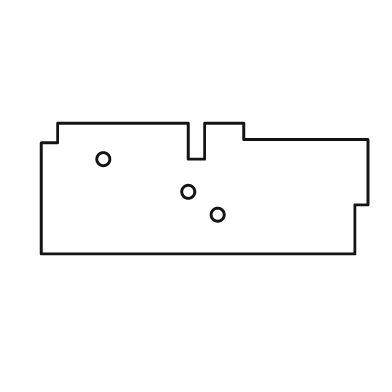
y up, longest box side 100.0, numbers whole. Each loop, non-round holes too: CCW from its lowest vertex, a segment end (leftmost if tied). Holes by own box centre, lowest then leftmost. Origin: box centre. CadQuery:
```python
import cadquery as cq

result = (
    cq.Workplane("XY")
    .moveTo(-50.0, -20.0)
    .lineTo(46.0, -20.0)
    .lineTo(46.0, -5.0)
    .lineTo(50.0, -5.0)
    .lineTo(50.0, 15.0)
    .lineTo(12.0, 15.0)
    .lineTo(12.0, 20.0)
    .lineTo(0.0, 20.0)
    .lineTo(0.0, 9.0)
    .lineTo(-5.0, 9.0)
    .lineTo(-5.0, 20.0)
    .lineTo(-45.0, 20.0)
    .lineTo(-45.0, 14.0)
    .lineTo(-50.0, 14.0)
    .close()
    .moveTo(4.0, -8.0)
    .circle(2.0)
    .moveTo(-5.0, -1.0)
    .circle(2.0)
    .moveTo(-31.0, 9.0)
    .circle(2.0)
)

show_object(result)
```